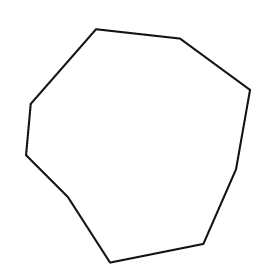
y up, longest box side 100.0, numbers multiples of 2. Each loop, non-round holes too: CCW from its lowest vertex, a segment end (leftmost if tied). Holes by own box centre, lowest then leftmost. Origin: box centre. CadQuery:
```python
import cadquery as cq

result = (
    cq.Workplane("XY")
    .moveTo(-12.0, -50.0)
    .lineTo(28.0, -42.0)
    .lineTo(42.0, -10.0)
    .lineTo(48.0, 24.0)
    .lineTo(18.0, 46.0)
    .lineTo(-18.0, 50.0)
    .lineTo(-46.0, 18.0)
    .lineTo(-48.0, -4.0)
    .lineTo(-30.0, -22.0)
    .close()
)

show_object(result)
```